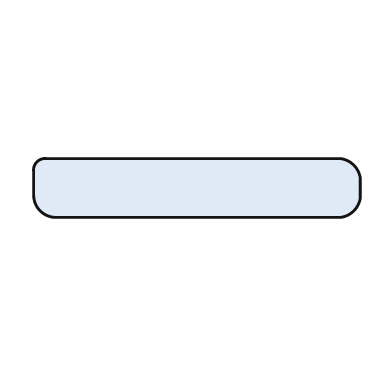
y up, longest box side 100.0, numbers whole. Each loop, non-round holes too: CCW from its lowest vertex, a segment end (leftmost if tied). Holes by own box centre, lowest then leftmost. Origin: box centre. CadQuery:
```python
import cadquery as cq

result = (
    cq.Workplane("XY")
    .moveTo(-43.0, -9.0)
    .lineTo(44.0, -9.0)
    .threePointArc((48.0, -7.0), (50.0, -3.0))
    .lineTo(50.0, 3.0)
    .threePointArc((48.0, 7.0), (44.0, 9.0))
    .lineTo(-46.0, 9.0)
    .threePointArc((-49.0, 8.0), (-50.0, 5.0))
    .lineTo(-50.0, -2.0)
    .threePointArc((-48.0, -7.0), (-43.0, -9.0))
    .close()
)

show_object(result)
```